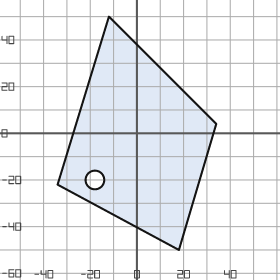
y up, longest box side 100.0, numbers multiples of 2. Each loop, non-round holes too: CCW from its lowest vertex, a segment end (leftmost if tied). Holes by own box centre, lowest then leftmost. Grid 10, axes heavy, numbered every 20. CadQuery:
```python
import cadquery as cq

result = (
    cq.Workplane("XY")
    .moveTo(18.0, -50.0)
    .lineTo(34.0, 4.0)
    .lineTo(-12.0, 50.0)
    .lineTo(-34.0, -22.0)
    .close()
    .moveTo(-18.0, -20.0)
    .circle(4.0)
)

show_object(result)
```